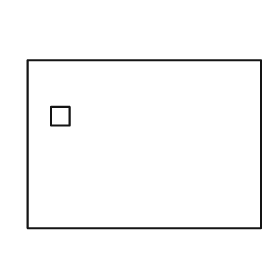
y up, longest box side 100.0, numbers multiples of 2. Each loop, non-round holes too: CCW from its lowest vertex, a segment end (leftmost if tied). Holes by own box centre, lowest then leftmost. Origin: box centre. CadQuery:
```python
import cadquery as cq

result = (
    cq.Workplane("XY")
    .moveTo(-50.0, -36.0)
    .lineTo(50.0, -36.0)
    .lineTo(50.0, 36.0)
    .lineTo(-50.0, 36.0)
    .close()
    .moveTo(-40.0, 8.0)
    .lineTo(-32.0, 8.0)
    .lineTo(-32.0, 16.0)
    .lineTo(-40.0, 16.0)
    .close()
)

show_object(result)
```